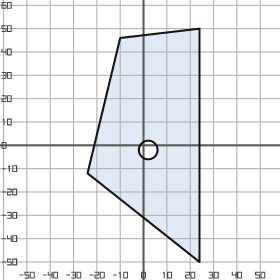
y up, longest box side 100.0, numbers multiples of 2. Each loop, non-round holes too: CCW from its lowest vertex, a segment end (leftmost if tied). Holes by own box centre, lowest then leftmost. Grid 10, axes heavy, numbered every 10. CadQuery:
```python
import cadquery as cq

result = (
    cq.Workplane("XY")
    .moveTo(24.0, -50.0)
    .lineTo(24.0, 50.0)
    .lineTo(-10.0, 46.0)
    .lineTo(-24.0, -12.0)
    .close()
    .moveTo(2.0, -2.0)
    .circle(4.0)
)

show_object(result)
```